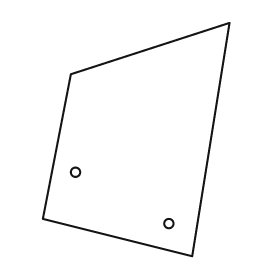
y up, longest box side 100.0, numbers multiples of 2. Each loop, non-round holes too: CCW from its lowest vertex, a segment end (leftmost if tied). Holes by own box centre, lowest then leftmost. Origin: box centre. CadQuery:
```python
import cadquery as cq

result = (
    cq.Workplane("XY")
    .moveTo(24.0, -50.0)
    .lineTo(40.0, 50.0)
    .lineTo(-28.0, 28.0)
    .lineTo(-40.0, -34.0)
    .close()
    .moveTo(14.0, -36.0)
    .circle(2.0)
    .moveTo(-26.0, -14.0)
    .circle(2.0)
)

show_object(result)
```